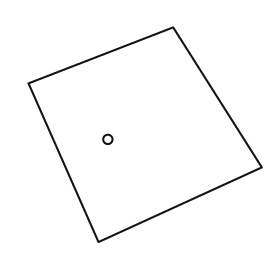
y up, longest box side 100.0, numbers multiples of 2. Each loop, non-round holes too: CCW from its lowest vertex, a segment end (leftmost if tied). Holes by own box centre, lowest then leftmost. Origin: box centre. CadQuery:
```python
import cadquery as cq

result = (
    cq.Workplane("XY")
    .moveTo(-20.0, -46.0)
    .lineTo(50.0, -14.0)
    .lineTo(12.0, 46.0)
    .lineTo(-50.0, 22.0)
    .close()
    .moveTo(-16.0, -2.0)
    .circle(2.0)
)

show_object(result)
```